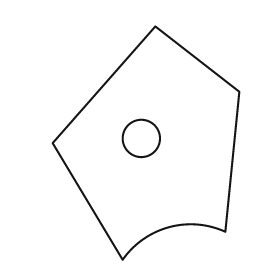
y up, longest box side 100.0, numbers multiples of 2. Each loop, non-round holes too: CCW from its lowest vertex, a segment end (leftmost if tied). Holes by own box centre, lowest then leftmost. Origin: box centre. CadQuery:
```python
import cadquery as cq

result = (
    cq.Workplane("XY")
    .moveTo(-10.0, -50.0)
    .threePointArc((10.0, -36.0), (34.0, -38.0))
    .lineTo(40.0, 22.0)
    .lineTo(4.0, 50.0)
    .lineTo(-40.0, 0.0)
    .close()
    .moveTo(-2.0, 2.0)
    .circle(8.0)
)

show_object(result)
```